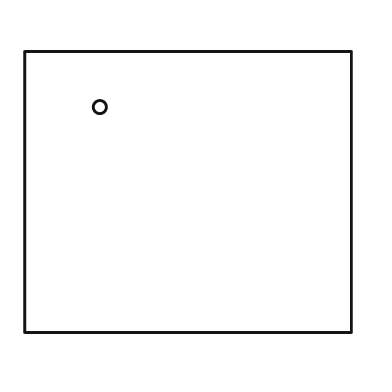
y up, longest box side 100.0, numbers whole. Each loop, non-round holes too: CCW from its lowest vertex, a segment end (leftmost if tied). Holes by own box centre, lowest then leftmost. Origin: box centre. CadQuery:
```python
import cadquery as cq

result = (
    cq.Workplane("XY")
    .moveTo(-50.0, -43.0)
    .lineTo(50.0, -43.0)
    .lineTo(50.0, 43.0)
    .lineTo(-50.0, 43.0)
    .close()
    .moveTo(-27.0, 26.0)
    .circle(2.0)
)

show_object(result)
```